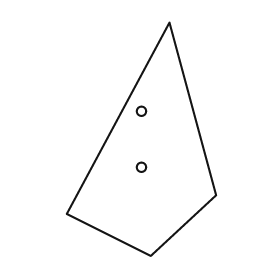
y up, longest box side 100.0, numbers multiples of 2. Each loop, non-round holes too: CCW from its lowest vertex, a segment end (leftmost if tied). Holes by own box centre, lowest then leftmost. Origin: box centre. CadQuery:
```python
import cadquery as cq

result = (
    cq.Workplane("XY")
    .moveTo(4.0, -50.0)
    .lineTo(32.0, -24.0)
    .lineTo(12.0, 50.0)
    .lineTo(-32.0, -32.0)
    .close()
    .moveTo(0.0, -12.0)
    .circle(2.0)
    .moveTo(0.0, 12.0)
    .circle(2.0)
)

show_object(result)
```